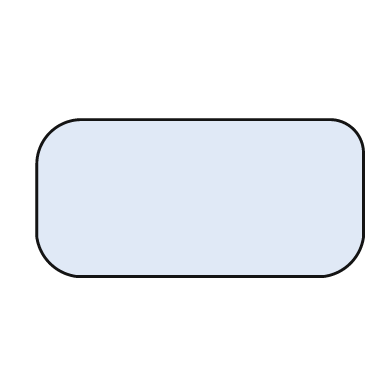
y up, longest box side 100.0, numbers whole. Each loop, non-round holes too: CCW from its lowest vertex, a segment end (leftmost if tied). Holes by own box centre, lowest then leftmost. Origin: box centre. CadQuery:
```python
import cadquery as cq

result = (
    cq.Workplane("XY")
    .moveTo(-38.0, -24.0)
    .lineTo(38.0, -24.0)
    .threePointArc((46.0, -20.0), (50.0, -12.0))
    .lineTo(50.0, 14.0)
    .threePointArc((47.0, 21.0), (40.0, 24.0))
    .lineTo(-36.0, 24.0)
    .threePointArc((-46.0, 20.0), (-50.0, 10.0))
    .lineTo(-50.0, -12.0)
    .threePointArc((-46.0, -20.0), (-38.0, -24.0))
    .close()
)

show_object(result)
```